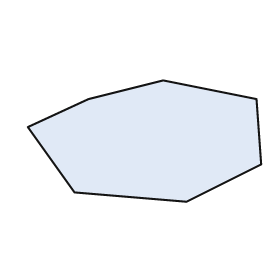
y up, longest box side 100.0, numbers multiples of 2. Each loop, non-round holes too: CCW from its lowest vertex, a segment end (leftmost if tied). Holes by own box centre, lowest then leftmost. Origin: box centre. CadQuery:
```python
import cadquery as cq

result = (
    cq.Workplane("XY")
    .moveTo(18.0, -26.0)
    .lineTo(50.0, -10.0)
    .lineTo(48.0, 18.0)
    .lineTo(8.0, 26.0)
    .lineTo(-24.0, 18.0)
    .lineTo(-50.0, 6.0)
    .lineTo(-30.0, -22.0)
    .close()
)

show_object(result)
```